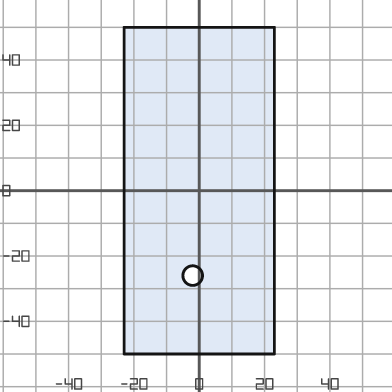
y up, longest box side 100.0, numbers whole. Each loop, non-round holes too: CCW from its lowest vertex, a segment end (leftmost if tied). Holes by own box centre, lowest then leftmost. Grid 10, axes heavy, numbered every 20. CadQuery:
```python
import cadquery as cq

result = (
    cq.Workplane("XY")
    .moveTo(-23.0, -50.0)
    .lineTo(23.0, -50.0)
    .lineTo(23.0, 50.0)
    .lineTo(-23.0, 50.0)
    .close()
    .moveTo(-2.0, -26.0)
    .circle(3.0)
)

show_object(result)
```